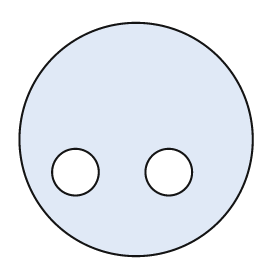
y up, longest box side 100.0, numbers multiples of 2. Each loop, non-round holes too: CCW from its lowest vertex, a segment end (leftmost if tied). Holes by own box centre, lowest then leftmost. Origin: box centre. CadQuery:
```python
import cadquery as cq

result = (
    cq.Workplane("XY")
    .moveTo(0.0, 0.0)
    .circle(50.0)
    .moveTo(-26.0, -14.0)
    .circle(10.0)
    .moveTo(14.0, -14.0)
    .circle(10.0)
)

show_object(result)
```